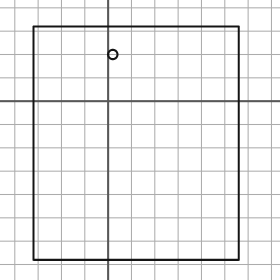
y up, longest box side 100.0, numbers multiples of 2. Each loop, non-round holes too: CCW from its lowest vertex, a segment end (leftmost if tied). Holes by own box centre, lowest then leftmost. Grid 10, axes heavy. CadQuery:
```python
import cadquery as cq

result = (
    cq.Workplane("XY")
    .moveTo(-32.0, -68.0)
    .lineTo(56.0, -68.0)
    .lineTo(56.0, 32.0)
    .lineTo(-32.0, 32.0)
    .close()
    .moveTo(2.0, 20.0)
    .circle(2.0)
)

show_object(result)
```